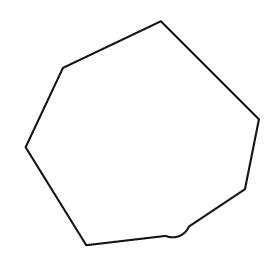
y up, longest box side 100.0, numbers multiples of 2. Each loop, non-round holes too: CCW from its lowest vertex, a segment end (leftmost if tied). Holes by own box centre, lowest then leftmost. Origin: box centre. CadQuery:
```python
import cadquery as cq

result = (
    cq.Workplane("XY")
    .moveTo(-24.0, -48.0)
    .lineTo(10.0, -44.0)
    .threePointArc((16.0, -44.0), (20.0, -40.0))
    .lineTo(44.0, -24.0)
    .lineTo(50.0, 6.0)
    .lineTo(8.0, 48.0)
    .lineTo(-34.0, 28.0)
    .lineTo(-50.0, -6.0)
    .close()
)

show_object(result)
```